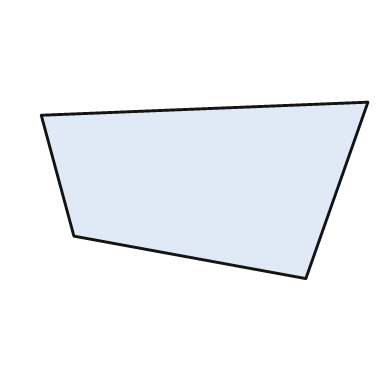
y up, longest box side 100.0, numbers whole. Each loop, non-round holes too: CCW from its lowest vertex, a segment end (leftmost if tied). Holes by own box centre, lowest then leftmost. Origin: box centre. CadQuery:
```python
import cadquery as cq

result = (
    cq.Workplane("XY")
    .moveTo(31.0, -27.0)
    .lineTo(50.0, 27.0)
    .lineTo(-50.0, 23.0)
    .lineTo(-40.0, -14.0)
    .close()
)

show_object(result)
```